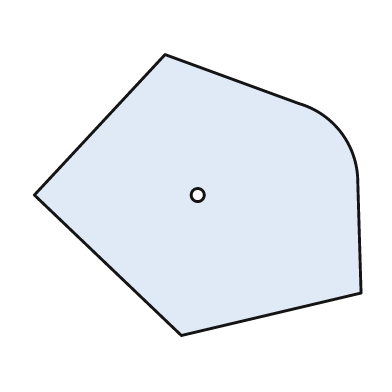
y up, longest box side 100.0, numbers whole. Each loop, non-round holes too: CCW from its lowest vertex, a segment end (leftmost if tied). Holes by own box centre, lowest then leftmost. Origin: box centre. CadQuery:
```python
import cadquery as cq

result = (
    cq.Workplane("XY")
    .moveTo(-5.0, -43.0)
    .lineTo(50.0, -30.0)
    .lineTo(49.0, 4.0)
    .threePointArc((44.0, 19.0), (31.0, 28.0))
    .lineTo(-10.0, 43.0)
    .lineTo(-50.0, 0.0)
    .close()
    .moveTo(0.0, 0.0)
    .circle(2.0)
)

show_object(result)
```